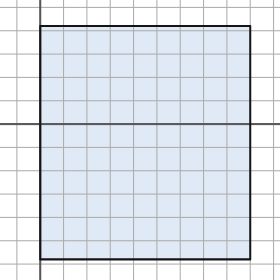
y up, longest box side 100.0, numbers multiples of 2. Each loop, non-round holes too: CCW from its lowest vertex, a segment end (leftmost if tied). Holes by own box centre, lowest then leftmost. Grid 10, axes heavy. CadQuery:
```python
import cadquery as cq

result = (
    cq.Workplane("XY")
    .moveTo(0.0, -58.0)
    .lineTo(90.0, -58.0)
    .lineTo(90.0, 42.0)
    .lineTo(0.0, 42.0)
    .close()
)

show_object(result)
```